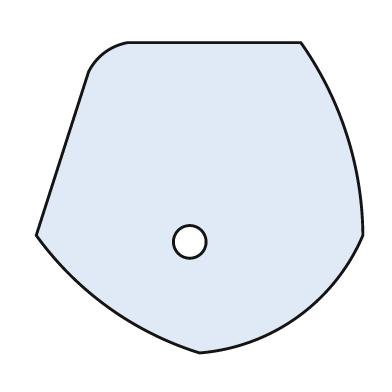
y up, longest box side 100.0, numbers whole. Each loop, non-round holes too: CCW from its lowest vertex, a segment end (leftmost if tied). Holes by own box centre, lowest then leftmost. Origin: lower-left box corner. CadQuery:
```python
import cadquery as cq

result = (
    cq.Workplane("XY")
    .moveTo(50.0, 0.0)
    .threePointArc((80.0, 11.0), (100.0, 36.0))
    .threePointArc((95.0, 67.0), (81.0, 95.0))
    .lineTo(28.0, 95.0)
    .threePointArc((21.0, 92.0), (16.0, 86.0))
    .lineTo(0.0, 36.0)
    .threePointArc((22.0, 14.0), (50.0, 0.0))
    .close()
    .moveTo(47.0, 34.0)
    .circle(5.0)
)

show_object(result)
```